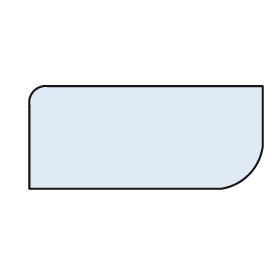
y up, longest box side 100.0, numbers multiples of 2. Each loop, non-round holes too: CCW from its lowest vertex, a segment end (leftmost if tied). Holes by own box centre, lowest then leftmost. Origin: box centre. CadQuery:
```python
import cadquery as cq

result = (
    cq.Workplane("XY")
    .moveTo(-50.0, -22.0)
    .lineTo(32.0, -22.0)
    .threePointArc((44.0, -16.0), (50.0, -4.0))
    .lineTo(50.0, 22.0)
    .lineTo(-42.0, 22.0)
    .threePointArc((-48.0, 20.0), (-50.0, 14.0))
    .close()
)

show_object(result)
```